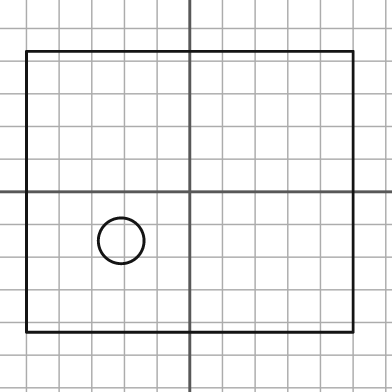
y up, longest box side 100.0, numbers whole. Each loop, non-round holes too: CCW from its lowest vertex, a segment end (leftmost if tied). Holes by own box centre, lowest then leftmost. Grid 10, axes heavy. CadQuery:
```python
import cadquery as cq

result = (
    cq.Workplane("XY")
    .moveTo(-50.0, -43.0)
    .lineTo(50.0, -43.0)
    .lineTo(50.0, 43.0)
    .lineTo(-50.0, 43.0)
    .close()
    .moveTo(-21.0, -15.0)
    .circle(7.0)
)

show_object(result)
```